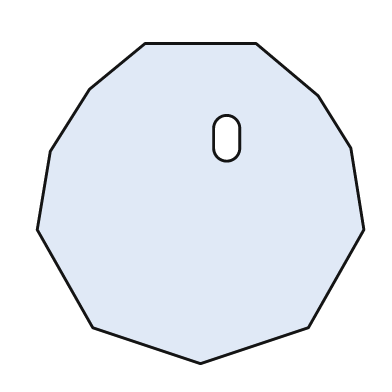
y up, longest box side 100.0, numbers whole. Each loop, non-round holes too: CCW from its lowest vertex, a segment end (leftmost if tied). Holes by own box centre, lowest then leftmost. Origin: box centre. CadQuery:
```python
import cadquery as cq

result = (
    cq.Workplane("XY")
    .moveTo(0.0, -49.0)
    .lineTo(33.0, -38.0)
    .lineTo(50.0, -8.0)
    .lineTo(46.0, 17.0)
    .lineTo(36.0, 33.0)
    .lineTo(17.0, 49.0)
    .lineTo(-17.0, 49.0)
    .lineTo(-34.0, 35.0)
    .lineTo(-46.0, 16.0)
    .lineTo(-50.0, -8.0)
    .lineTo(-33.0, -38.0)
    .close()
    .moveTo(4.0, 17.0)
    .threePointArc((8.0, 13.0), (12.0, 17.0))
    .lineTo(12.0, 23.0)
    .threePointArc((8.0, 27.0), (4.0, 23.0))
    .close()
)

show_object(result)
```